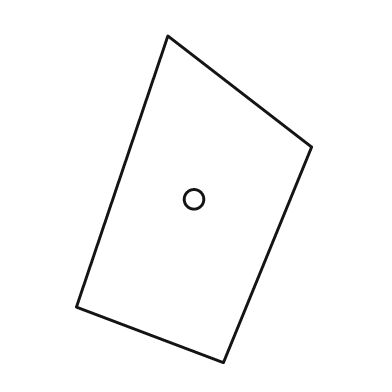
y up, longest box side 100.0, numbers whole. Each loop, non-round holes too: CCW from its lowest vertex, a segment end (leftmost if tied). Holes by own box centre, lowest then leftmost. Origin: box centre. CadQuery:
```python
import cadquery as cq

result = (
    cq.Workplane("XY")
    .moveTo(9.0, -50.0)
    .lineTo(36.0, 16.0)
    .lineTo(-8.0, 50.0)
    .lineTo(-36.0, -33.0)
    .close()
    .moveTo(0.0, 0.0)
    .circle(3.0)
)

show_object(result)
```